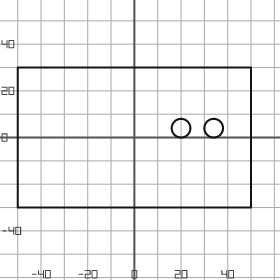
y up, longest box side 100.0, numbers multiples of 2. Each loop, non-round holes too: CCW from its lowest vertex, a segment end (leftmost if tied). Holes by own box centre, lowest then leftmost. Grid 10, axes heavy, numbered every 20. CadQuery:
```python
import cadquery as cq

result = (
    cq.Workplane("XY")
    .moveTo(-50.0, -30.0)
    .lineTo(50.0, -30.0)
    .lineTo(50.0, 30.0)
    .lineTo(-50.0, 30.0)
    .close()
    .moveTo(20.0, 4.0)
    .circle(4.0)
    .moveTo(34.0, 4.0)
    .circle(4.0)
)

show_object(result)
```